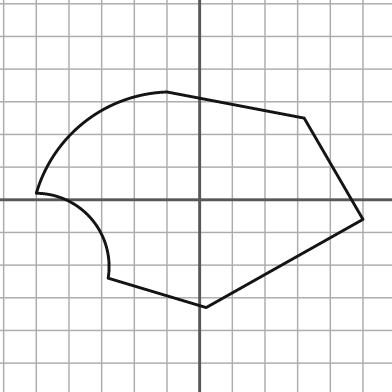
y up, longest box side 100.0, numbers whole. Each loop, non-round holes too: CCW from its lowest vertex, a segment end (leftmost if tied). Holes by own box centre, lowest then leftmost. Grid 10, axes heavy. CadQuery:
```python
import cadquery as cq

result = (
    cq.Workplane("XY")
    .moveTo(2.0, -33.0)
    .lineTo(50.0, -6.0)
    .lineTo(32.0, 25.0)
    .lineTo(-10.0, 33.0)
    .threePointArc((-35.0, 24.0), (-50.0, 2.0))
    .threePointArc((-33.0, -6.0), (-28.0, -24.0))
    .close()
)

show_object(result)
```